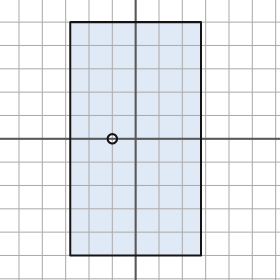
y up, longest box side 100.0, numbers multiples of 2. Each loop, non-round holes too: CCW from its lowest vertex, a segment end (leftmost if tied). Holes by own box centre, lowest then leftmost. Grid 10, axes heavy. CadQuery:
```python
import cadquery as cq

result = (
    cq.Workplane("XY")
    .moveTo(-28.0, -50.0)
    .lineTo(28.0, -50.0)
    .lineTo(28.0, 50.0)
    .lineTo(-28.0, 50.0)
    .close()
    .moveTo(-10.0, 0.0)
    .circle(2.0)
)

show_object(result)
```